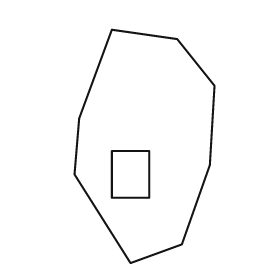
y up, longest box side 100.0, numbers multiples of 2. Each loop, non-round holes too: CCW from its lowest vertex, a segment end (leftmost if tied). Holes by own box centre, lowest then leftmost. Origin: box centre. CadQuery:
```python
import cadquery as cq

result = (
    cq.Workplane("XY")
    .moveTo(-6.0, -50.0)
    .lineTo(16.0, -42.0)
    .lineTo(28.0, -8.0)
    .lineTo(30.0, 26.0)
    .lineTo(14.0, 46.0)
    .lineTo(-14.0, 50.0)
    .lineTo(-28.0, 12.0)
    .lineTo(-30.0, -12.0)
    .close()
    .moveTo(-14.0, -22.0)
    .lineTo(2.0, -22.0)
    .lineTo(2.0, -2.0)
    .lineTo(-14.0, -2.0)
    .close()
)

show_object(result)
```